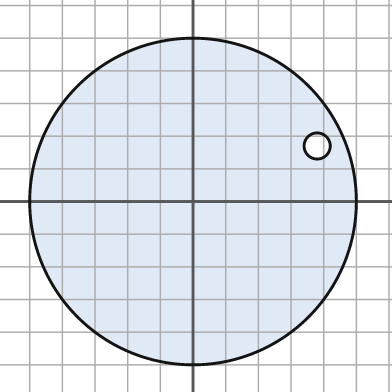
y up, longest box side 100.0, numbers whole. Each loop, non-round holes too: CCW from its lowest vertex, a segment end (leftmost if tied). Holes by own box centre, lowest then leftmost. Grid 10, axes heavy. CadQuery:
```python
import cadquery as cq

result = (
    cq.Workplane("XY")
    .moveTo(0.0, 0.0)
    .circle(50.0)
    .moveTo(38.0, 17.0)
    .circle(4.0)
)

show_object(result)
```